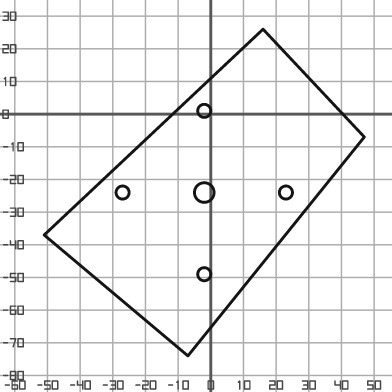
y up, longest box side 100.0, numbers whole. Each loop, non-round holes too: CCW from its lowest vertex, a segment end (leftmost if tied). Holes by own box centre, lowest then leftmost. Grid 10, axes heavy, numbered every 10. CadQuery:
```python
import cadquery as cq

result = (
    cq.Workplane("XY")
    .moveTo(-7.0, -74.0)
    .lineTo(47.0, -7.0)
    .lineTo(16.0, 26.0)
    .lineTo(-51.0, -37.0)
    .close()
    .moveTo(-2.0, -49.0)
    .circle(2.0)
    .moveTo(-27.0, -24.0)
    .circle(2.0)
    .moveTo(-2.0, -24.0)
    .circle(3.0)
    .moveTo(23.0, -24.0)
    .circle(2.0)
    .moveTo(-2.0, 1.0)
    .circle(2.0)
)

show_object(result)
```